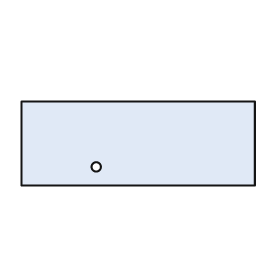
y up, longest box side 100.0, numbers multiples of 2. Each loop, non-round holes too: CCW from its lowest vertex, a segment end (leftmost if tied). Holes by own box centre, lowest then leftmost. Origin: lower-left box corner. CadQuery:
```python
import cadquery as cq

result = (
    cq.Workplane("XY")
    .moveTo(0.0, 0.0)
    .lineTo(100.0, 0.0)
    .lineTo(100.0, 36.0)
    .lineTo(0.0, 36.0)
    .close()
    .moveTo(32.0, 8.0)
    .circle(2.0)
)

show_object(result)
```